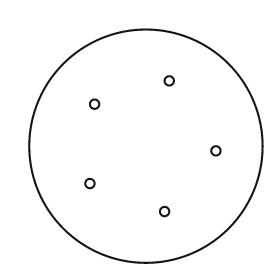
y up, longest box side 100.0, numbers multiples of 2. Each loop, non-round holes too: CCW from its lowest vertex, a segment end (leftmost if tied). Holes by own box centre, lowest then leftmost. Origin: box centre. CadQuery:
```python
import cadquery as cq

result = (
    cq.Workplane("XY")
    .moveTo(0.0, 0.0)
    .circle(50.0)
    .moveTo(8.0, -28.0)
    .circle(2.0)
    .moveTo(-24.0, -16.0)
    .circle(2.0)
    .moveTo(30.0, -2.0)
    .circle(2.0)
    .moveTo(-22.0, 18.0)
    .circle(2.0)
    .moveTo(10.0, 28.0)
    .circle(2.0)
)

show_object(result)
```